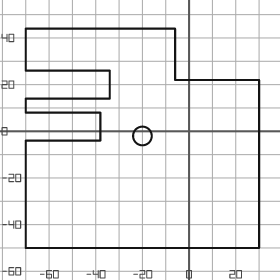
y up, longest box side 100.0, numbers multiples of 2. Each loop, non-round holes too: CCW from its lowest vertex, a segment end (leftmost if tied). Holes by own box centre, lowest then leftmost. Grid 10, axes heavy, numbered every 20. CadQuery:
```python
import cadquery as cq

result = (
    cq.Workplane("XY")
    .moveTo(-70.0, -50.0)
    .lineTo(30.0, -50.0)
    .lineTo(30.0, 22.0)
    .lineTo(-6.0, 22.0)
    .lineTo(-6.0, 44.0)
    .lineTo(-70.0, 44.0)
    .lineTo(-70.0, 26.0)
    .lineTo(-34.0, 26.0)
    .lineTo(-34.0, 14.0)
    .lineTo(-70.0, 14.0)
    .lineTo(-70.0, 8.0)
    .lineTo(-38.0, 8.0)
    .lineTo(-38.0, -4.0)
    .lineTo(-70.0, -4.0)
    .close()
    .moveTo(-20.0, -2.0)
    .circle(4.0)
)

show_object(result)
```